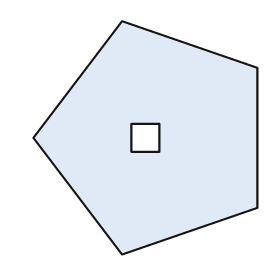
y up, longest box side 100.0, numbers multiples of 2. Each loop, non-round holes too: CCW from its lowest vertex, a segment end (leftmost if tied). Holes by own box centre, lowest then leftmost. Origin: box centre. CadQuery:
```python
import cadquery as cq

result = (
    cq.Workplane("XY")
    .moveTo(-10.0, -50.0)
    .lineTo(48.0, -30.0)
    .lineTo(48.0, 30.0)
    .lineTo(-10.0, 50.0)
    .lineTo(-48.0, 0.0)
    .close()
    .moveTo(-6.0, -6.0)
    .lineTo(6.0, -6.0)
    .lineTo(6.0, 6.0)
    .lineTo(-6.0, 6.0)
    .close()
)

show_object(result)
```